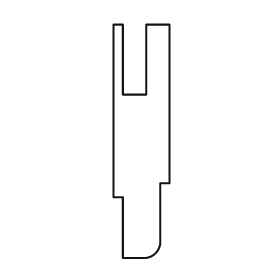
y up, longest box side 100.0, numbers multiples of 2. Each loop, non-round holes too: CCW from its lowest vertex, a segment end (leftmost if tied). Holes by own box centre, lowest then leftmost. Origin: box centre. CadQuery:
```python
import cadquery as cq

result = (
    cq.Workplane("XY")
    .moveTo(-8.0, -50.0)
    .lineTo(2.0, -50.0)
    .threePointArc((6.0, -48.0), (8.0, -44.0))
    .lineTo(8.0, -18.0)
    .lineTo(12.0, -18.0)
    .lineTo(12.0, 50.0)
    .lineTo(2.0, 50.0)
    .lineTo(2.0, 20.0)
    .lineTo(-8.0, 20.0)
    .lineTo(-8.0, 50.0)
    .lineTo(-12.0, 50.0)
    .lineTo(-12.0, -24.0)
    .lineTo(-8.0, -24.0)
    .close()
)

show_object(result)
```